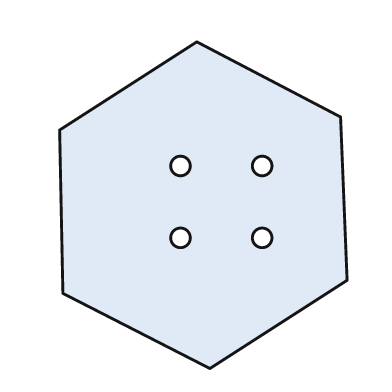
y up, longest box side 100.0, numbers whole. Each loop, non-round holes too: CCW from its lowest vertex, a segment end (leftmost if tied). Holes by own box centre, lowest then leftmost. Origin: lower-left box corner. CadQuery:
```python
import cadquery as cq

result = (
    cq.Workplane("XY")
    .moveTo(46.0, 0.0)
    .lineTo(88.0, 27.0)
    .lineTo(86.0, 77.0)
    .lineTo(42.0, 100.0)
    .lineTo(0.0, 73.0)
    .lineTo(1.0, 23.0)
    .close()
    .moveTo(37.0, 40.0)
    .circle(3.0)
    .moveTo(62.0, 40.0)
    .circle(3.0)
    .moveTo(37.0, 62.0)
    .circle(3.0)
    .moveTo(62.0, 62.0)
    .circle(3.0)
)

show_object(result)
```